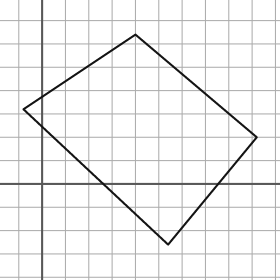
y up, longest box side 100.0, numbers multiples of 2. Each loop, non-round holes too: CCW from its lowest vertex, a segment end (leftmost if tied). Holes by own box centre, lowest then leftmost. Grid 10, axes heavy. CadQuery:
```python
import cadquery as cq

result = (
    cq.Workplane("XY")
    .moveTo(54.0, -26.0)
    .lineTo(92.0, 20.0)
    .lineTo(40.0, 64.0)
    .lineTo(-8.0, 32.0)
    .close()
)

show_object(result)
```